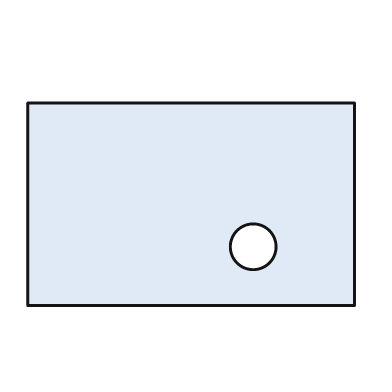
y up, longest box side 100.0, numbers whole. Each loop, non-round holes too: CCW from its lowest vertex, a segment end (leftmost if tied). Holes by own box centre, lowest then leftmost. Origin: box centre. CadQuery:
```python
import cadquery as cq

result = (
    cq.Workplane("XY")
    .moveTo(-50.0, -31.0)
    .lineTo(50.0, -31.0)
    .lineTo(50.0, 31.0)
    .lineTo(-50.0, 31.0)
    .close()
    .moveTo(19.0, -13.0)
    .circle(7.0)
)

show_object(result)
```